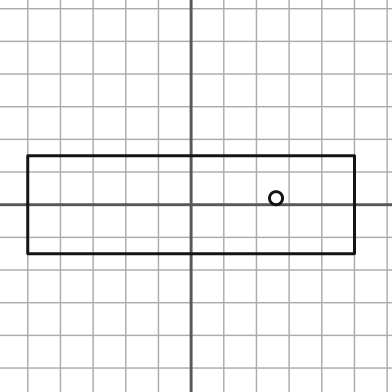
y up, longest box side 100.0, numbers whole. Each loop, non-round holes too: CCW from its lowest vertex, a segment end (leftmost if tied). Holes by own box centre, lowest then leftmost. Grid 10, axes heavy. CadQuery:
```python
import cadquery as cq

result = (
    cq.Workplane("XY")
    .moveTo(-50.0, -15.0)
    .lineTo(50.0, -15.0)
    .lineTo(50.0, 15.0)
    .lineTo(-50.0, 15.0)
    .close()
    .moveTo(26.0, 2.0)
    .circle(2.0)
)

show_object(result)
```